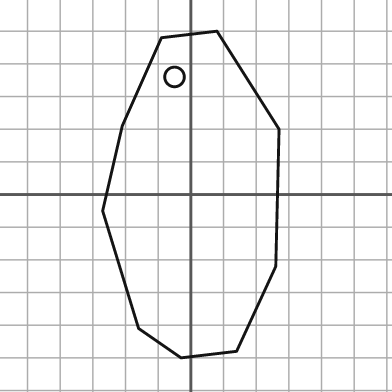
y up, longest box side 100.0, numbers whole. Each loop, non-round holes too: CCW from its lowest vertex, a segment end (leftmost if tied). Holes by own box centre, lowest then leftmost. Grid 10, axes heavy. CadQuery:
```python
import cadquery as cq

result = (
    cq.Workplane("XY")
    .moveTo(-3.0, -50.0)
    .lineTo(14.0, -48.0)
    .lineTo(26.0, -22.0)
    .lineTo(27.0, 20.0)
    .lineTo(8.0, 50.0)
    .lineTo(-9.0, 48.0)
    .lineTo(-21.0, 21.0)
    .lineTo(-27.0, -5.0)
    .lineTo(-16.0, -41.0)
    .close()
    .moveTo(-5.0, 36.0)
    .circle(3.0)
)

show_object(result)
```